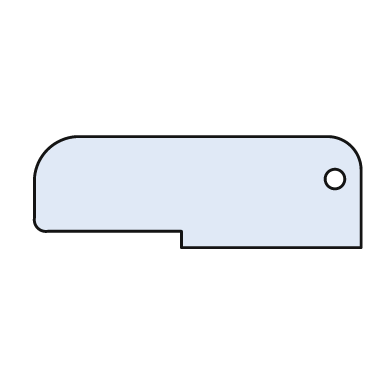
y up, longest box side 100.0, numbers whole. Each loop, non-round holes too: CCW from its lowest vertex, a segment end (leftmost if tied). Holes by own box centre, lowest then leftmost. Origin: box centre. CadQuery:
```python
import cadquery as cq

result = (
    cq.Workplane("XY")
    .moveTo(-5.0, -17.0)
    .lineTo(50.0, -17.0)
    .lineTo(50.0, 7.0)
    .threePointArc((47.0, 14.0), (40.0, 17.0))
    .lineTo(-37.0, 17.0)
    .threePointArc((-46.0, 13.0), (-50.0, 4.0))
    .lineTo(-50.0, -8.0)
    .threePointArc((-49.0, -11.0), (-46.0, -12.0))
    .lineTo(-5.0, -12.0)
    .close()
    .moveTo(42.0, 4.0)
    .circle(3.0)
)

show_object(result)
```